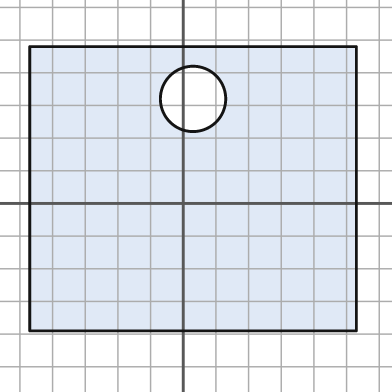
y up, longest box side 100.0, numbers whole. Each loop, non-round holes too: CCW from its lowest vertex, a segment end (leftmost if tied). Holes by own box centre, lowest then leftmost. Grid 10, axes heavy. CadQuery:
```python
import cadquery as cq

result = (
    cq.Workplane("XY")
    .moveTo(-47.0, -39.0)
    .lineTo(53.0, -39.0)
    .lineTo(53.0, 48.0)
    .lineTo(-47.0, 48.0)
    .close()
    .moveTo(3.0, 32.0)
    .circle(10.0)
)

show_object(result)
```